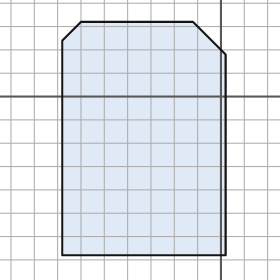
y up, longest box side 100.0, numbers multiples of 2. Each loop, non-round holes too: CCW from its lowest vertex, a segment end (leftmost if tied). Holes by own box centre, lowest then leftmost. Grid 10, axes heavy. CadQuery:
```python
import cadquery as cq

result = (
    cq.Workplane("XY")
    .moveTo(-68.0, -68.0)
    .lineTo(2.0, -68.0)
    .lineTo(2.0, 18.0)
    .lineTo(-12.0, 32.0)
    .lineTo(-60.0, 32.0)
    .lineTo(-68.0, 24.0)
    .close()
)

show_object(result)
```